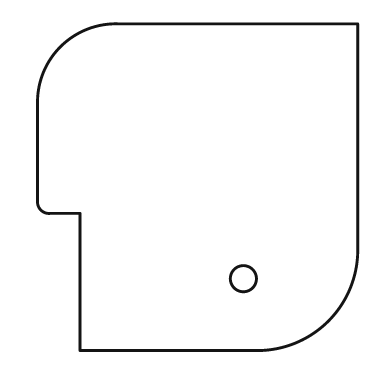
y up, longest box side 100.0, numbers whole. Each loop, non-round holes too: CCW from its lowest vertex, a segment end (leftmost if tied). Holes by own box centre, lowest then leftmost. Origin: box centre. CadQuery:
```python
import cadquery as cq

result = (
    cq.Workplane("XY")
    .moveTo(-36.0, -50.0)
    .lineTo(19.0, -50.0)
    .threePointArc((40.0, -41.0), (49.0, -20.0))
    .lineTo(49.0, 50.0)
    .lineTo(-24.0, 50.0)
    .threePointArc((-42.0, 43.0), (-49.0, 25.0))
    .lineTo(-49.0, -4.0)
    .threePointArc((-48.0, -7.0), (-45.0, -8.0))
    .lineTo(-36.0, -8.0)
    .close()
    .moveTo(14.0, -28.0)
    .circle(4.0)
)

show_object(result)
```